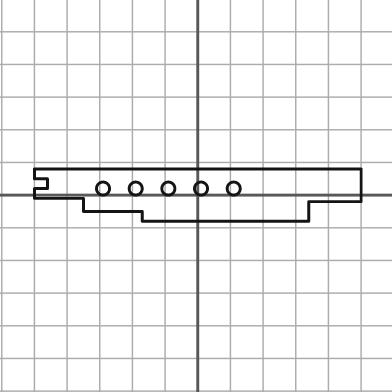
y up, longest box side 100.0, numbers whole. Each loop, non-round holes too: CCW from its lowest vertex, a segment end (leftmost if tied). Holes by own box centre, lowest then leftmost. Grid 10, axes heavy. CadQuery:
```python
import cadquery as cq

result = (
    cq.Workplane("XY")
    .moveTo(-17.0, -8.0)
    .lineTo(34.0, -8.0)
    .lineTo(34.0, -2.0)
    .lineTo(50.0, -2.0)
    .lineTo(50.0, 8.0)
    .lineTo(-50.0, 8.0)
    .lineTo(-50.0, 5.0)
    .lineTo(-46.0, 5.0)
    .lineTo(-46.0, 2.0)
    .lineTo(-50.0, 2.0)
    .lineTo(-50.0, -1.0)
    .lineTo(-35.0, -1.0)
    .lineTo(-35.0, -5.0)
    .lineTo(-17.0, -5.0)
    .close()
    .moveTo(-29.0, 2.0)
    .circle(2.0)
    .moveTo(-19.0, 2.0)
    .circle(2.0)
    .moveTo(-9.0, 2.0)
    .circle(2.0)
    .moveTo(1.0, 2.0)
    .circle(2.0)
    .moveTo(11.0, 2.0)
    .circle(2.0)
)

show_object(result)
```